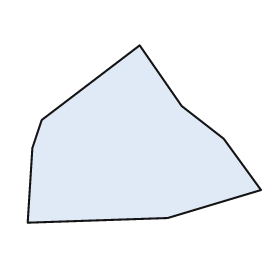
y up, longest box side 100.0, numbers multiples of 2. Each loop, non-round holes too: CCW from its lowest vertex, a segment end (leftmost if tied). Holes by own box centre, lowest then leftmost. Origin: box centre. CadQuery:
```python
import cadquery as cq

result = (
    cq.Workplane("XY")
    .moveTo(-50.0, -38.0)
    .lineTo(10.0, -36.0)
    .lineTo(50.0, -24.0)
    .lineTo(34.0, -2.0)
    .lineTo(16.0, 12.0)
    .lineTo(-2.0, 38.0)
    .lineTo(-44.0, 6.0)
    .lineTo(-48.0, -6.0)
    .close()
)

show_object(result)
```